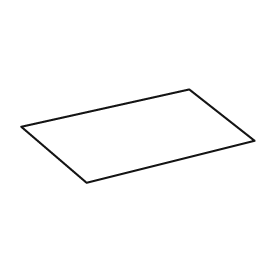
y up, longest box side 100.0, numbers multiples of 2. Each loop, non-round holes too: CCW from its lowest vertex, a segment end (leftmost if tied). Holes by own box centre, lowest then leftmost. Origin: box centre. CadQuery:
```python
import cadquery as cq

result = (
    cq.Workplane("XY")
    .moveTo(-22.0, -20.0)
    .lineTo(50.0, -2.0)
    .lineTo(22.0, 20.0)
    .lineTo(-50.0, 4.0)
    .close()
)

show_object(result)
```